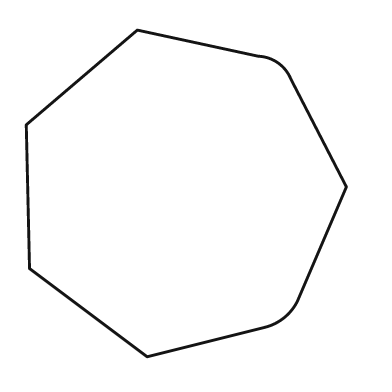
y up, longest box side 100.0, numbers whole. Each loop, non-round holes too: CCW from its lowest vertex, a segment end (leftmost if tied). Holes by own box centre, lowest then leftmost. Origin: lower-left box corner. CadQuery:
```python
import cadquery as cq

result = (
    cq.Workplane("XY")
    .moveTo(37.0, 0.0)
    .lineTo(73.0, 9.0)
    .threePointArc((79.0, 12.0), (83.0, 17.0))
    .lineTo(98.0, 52.0)
    .lineTo(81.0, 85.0)
    .threePointArc((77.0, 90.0), (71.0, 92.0))
    .lineTo(34.0, 100.0)
    .lineTo(0.0, 71.0)
    .lineTo(1.0, 27.0)
    .close()
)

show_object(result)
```